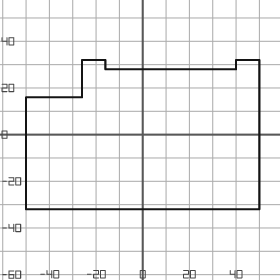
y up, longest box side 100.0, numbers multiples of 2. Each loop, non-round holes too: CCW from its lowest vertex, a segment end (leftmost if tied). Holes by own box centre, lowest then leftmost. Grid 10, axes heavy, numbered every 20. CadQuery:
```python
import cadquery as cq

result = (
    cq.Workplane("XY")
    .moveTo(-50.0, -32.0)
    .lineTo(50.0, -32.0)
    .lineTo(50.0, 32.0)
    .lineTo(40.0, 32.0)
    .lineTo(40.0, 28.0)
    .lineTo(-16.0, 28.0)
    .lineTo(-16.0, 32.0)
    .lineTo(-26.0, 32.0)
    .lineTo(-26.0, 16.0)
    .lineTo(-50.0, 16.0)
    .close()
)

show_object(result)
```